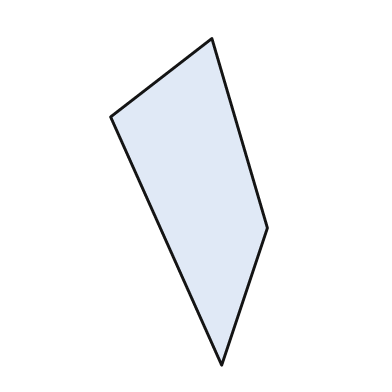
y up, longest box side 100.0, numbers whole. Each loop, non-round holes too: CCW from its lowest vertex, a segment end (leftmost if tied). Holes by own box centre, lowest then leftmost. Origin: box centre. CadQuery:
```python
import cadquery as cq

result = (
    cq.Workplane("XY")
    .moveTo(10.0, -50.0)
    .lineTo(24.0, -8.0)
    .lineTo(7.0, 50.0)
    .lineTo(-24.0, 26.0)
    .close()
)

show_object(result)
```